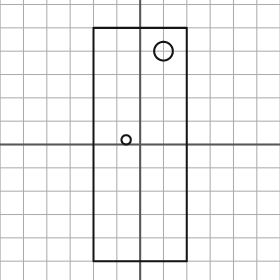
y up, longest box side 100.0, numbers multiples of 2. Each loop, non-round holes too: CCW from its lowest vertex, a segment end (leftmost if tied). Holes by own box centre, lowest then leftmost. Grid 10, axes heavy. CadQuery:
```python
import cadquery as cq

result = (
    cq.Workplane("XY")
    .moveTo(-20.0, -50.0)
    .lineTo(20.0, -50.0)
    .lineTo(20.0, 50.0)
    .lineTo(-20.0, 50.0)
    .close()
    .moveTo(-6.0, 2.0)
    .circle(2.0)
    .moveTo(10.0, 40.0)
    .circle(4.0)
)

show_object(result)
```